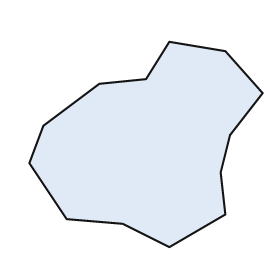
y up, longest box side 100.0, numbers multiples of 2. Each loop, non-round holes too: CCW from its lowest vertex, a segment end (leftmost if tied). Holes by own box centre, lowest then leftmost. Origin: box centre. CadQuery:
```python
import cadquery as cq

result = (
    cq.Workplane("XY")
    .moveTo(10.0, -44.0)
    .lineTo(34.0, -30.0)
    .lineTo(32.0, -12.0)
    .lineTo(36.0, 4.0)
    .lineTo(50.0, 22.0)
    .lineTo(34.0, 40.0)
    .lineTo(10.0, 44.0)
    .lineTo(0.0, 28.0)
    .lineTo(-20.0, 26.0)
    .lineTo(-44.0, 8.0)
    .lineTo(-50.0, -8.0)
    .lineTo(-34.0, -32.0)
    .lineTo(-10.0, -34.0)
    .close()
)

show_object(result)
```